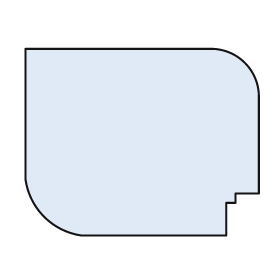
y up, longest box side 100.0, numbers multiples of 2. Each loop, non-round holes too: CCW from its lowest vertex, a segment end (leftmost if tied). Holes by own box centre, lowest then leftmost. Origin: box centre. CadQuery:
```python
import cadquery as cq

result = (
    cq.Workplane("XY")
    .moveTo(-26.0, -40.0)
    .lineTo(36.0, -40.0)
    .lineTo(36.0, -26.0)
    .lineTo(40.0, -26.0)
    .lineTo(40.0, -22.0)
    .lineTo(50.0, -22.0)
    .lineTo(50.0, 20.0)
    .threePointArc((44.0, 34.0), (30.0, 40.0))
    .lineTo(-50.0, 40.0)
    .lineTo(-50.0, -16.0)
    .threePointArc((-42.0, -32.0), (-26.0, -40.0))
    .close()
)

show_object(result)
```